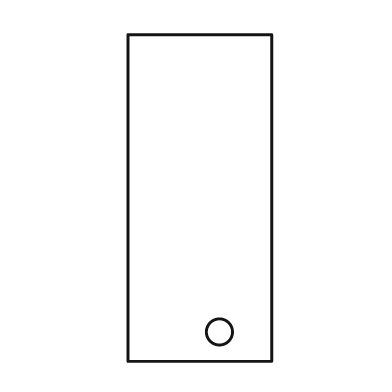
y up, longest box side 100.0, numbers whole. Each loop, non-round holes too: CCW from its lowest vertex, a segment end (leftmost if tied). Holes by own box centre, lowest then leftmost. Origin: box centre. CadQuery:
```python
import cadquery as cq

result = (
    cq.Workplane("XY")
    .moveTo(-22.0, -50.0)
    .lineTo(22.0, -50.0)
    .lineTo(22.0, 50.0)
    .lineTo(-22.0, 50.0)
    .close()
    .moveTo(6.0, -41.0)
    .circle(4.0)
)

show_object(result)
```